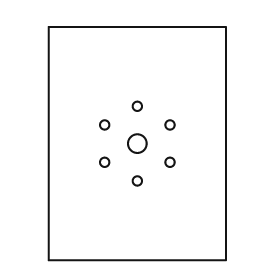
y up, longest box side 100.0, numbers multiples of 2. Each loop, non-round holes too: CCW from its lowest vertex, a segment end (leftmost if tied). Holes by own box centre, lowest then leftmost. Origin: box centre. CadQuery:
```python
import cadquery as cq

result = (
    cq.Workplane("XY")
    .moveTo(-38.0, -50.0)
    .lineTo(38.0, -50.0)
    .lineTo(38.0, 50.0)
    .lineTo(-38.0, 50.0)
    .close()
    .moveTo(0.0, -16.0)
    .circle(2.0)
    .moveTo(-14.0, -8.0)
    .circle(2.0)
    .moveTo(14.0, -8.0)
    .circle(2.0)
    .moveTo(0.0, 0.0)
    .circle(4.0)
    .moveTo(-14.0, 8.0)
    .circle(2.0)
    .moveTo(14.0, 8.0)
    .circle(2.0)
    .moveTo(0.0, 16.0)
    .circle(2.0)
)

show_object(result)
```